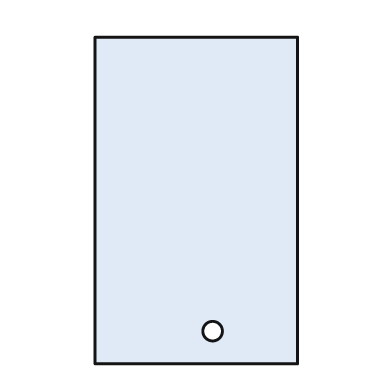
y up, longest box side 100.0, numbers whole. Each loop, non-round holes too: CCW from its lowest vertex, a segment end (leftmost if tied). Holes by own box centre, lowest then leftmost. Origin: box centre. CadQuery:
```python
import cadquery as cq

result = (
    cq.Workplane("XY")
    .moveTo(-31.0, -50.0)
    .lineTo(31.0, -50.0)
    .lineTo(31.0, 50.0)
    .lineTo(-31.0, 50.0)
    .close()
    .moveTo(5.0, -40.0)
    .circle(3.0)
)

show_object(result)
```